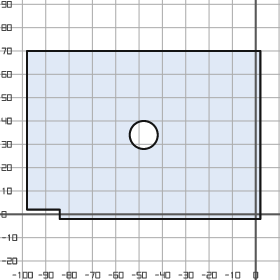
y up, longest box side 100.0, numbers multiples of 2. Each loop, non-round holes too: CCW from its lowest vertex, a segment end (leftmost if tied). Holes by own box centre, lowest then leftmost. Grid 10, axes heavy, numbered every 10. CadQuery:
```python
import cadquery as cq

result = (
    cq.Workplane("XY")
    .moveTo(-84.0, -2.0)
    .lineTo(2.0, -2.0)
    .lineTo(2.0, 70.0)
    .lineTo(-98.0, 70.0)
    .lineTo(-98.0, 2.0)
    .lineTo(-84.0, 2.0)
    .close()
    .moveTo(-48.0, 34.0)
    .circle(6.0)
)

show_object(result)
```